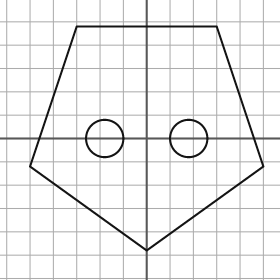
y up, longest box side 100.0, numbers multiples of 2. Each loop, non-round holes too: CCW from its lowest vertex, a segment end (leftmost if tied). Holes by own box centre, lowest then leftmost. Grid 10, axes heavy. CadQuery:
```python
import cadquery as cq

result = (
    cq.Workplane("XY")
    .moveTo(0.0, -48.0)
    .lineTo(50.0, -12.0)
    .lineTo(30.0, 48.0)
    .lineTo(-30.0, 48.0)
    .lineTo(-50.0, -12.0)
    .close()
    .moveTo(-18.0, 0.0)
    .circle(8.0)
    .moveTo(18.0, 0.0)
    .circle(8.0)
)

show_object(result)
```